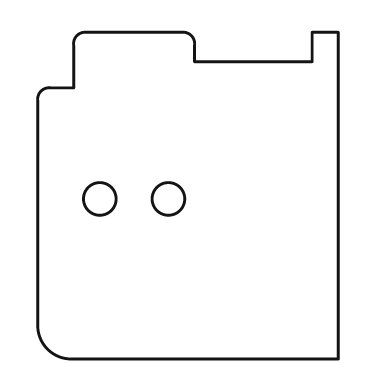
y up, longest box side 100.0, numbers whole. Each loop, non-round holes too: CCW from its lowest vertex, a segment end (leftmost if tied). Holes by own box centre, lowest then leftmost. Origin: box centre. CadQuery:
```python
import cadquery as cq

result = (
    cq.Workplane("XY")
    .moveTo(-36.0, -50.0)
    .lineTo(46.0, -50.0)
    .lineTo(46.0, 50.0)
    .lineTo(38.0, 50.0)
    .lineTo(38.0, 41.0)
    .lineTo(2.0, 41.0)
    .lineTo(2.0, 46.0)
    .threePointArc((1.0, 49.0), (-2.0, 50.0))
    .lineTo(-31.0, 50.0)
    .threePointArc((-34.0, 49.0), (-35.0, 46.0))
    .lineTo(-35.0, 33.0)
    .lineTo(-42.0, 33.0)
    .threePointArc((-45.0, 32.0), (-46.0, 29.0))
    .lineTo(-46.0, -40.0)
    .threePointArc((-43.0, -47.0), (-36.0, -50.0))
    .close()
    .moveTo(-27.0, -1.0)
    .circle(5.0)
    .moveTo(-6.0, -1.0)
    .circle(5.0)
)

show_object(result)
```